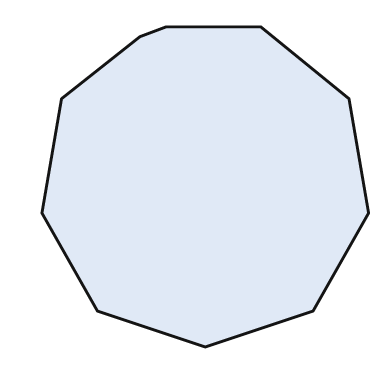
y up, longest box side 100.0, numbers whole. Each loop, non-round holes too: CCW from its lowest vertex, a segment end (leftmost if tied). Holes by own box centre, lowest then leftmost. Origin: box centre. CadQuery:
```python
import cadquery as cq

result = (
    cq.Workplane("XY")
    .moveTo(0.0, -49.0)
    .lineTo(33.0, -38.0)
    .lineTo(50.0, -8.0)
    .lineTo(44.0, 27.0)
    .lineTo(17.0, 49.0)
    .lineTo(-12.0, 49.0)
    .lineTo(-20.0, 46.0)
    .lineTo(-44.0, 27.0)
    .lineTo(-50.0, -8.0)
    .lineTo(-33.0, -38.0)
    .close()
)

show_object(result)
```